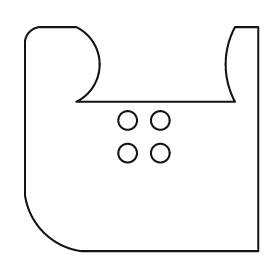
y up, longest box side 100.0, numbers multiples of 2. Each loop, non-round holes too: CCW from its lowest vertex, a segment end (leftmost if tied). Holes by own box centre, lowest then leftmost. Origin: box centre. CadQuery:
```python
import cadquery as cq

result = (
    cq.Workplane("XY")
    .moveTo(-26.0, -48.0)
    .lineTo(50.0, -48.0)
    .lineTo(50.0, 48.0)
    .lineTo(40.0, 48.0)
    .threePointArc((36.0, 32.0), (40.0, 16.0))
    .lineTo(-28.0, 16.0)
    .threePointArc((-18.0, 32.0), (-28.0, 48.0))
    .lineTo(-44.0, 48.0)
    .threePointArc((-48.0, 46.0), (-50.0, 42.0))
    .lineTo(-50.0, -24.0)
    .threePointArc((-42.0, -40.0), (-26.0, -48.0))
    .close()
    .moveTo(-6.0, -6.0)
    .circle(4.0)
    .moveTo(8.0, -6.0)
    .circle(4.0)
    .moveTo(-6.0, 8.0)
    .circle(4.0)
    .moveTo(8.0, 8.0)
    .circle(4.0)
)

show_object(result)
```